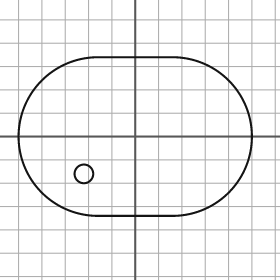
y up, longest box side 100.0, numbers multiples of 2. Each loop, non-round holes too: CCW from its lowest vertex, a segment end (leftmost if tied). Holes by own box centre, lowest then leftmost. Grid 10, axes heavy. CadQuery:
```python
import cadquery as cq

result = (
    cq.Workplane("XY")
    .moveTo(-16.0, -34.0)
    .lineTo(16.0, -34.0)
    .threePointArc((50.0, 0.0), (16.0, 34.0))
    .lineTo(-16.0, 34.0)
    .threePointArc((-50.0, 0.0), (-16.0, -34.0))
    .close()
    .moveTo(-22.0, -16.0)
    .circle(4.0)
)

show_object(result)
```